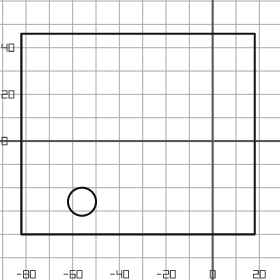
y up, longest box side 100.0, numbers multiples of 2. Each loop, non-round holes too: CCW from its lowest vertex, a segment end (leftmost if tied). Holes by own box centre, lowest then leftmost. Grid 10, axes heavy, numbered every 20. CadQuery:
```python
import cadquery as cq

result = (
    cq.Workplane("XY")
    .moveTo(-82.0, -40.0)
    .lineTo(18.0, -40.0)
    .lineTo(18.0, 46.0)
    .lineTo(-82.0, 46.0)
    .close()
    .moveTo(-56.0, -26.0)
    .circle(6.0)
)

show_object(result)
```